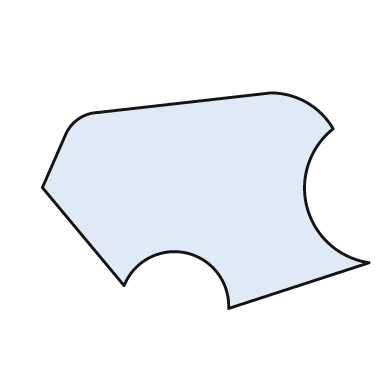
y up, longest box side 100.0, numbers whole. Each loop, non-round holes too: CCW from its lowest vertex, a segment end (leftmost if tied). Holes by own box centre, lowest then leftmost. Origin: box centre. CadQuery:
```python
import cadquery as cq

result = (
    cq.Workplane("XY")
    .moveTo(7.0, -33.0)
    .lineTo(50.0, -19.0)
    .threePointArc((31.0, -2.0), (39.0, 22.0))
    .threePointArc((31.0, 30.0), (20.0, 33.0))
    .lineTo(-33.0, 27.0)
    .threePointArc((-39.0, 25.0), (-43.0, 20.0))
    .lineTo(-50.0, 4.0)
    .lineTo(-25.0, -26.0)
    .threePointArc((-6.0, -16.0), (7.0, -33.0))
    .close()
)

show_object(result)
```